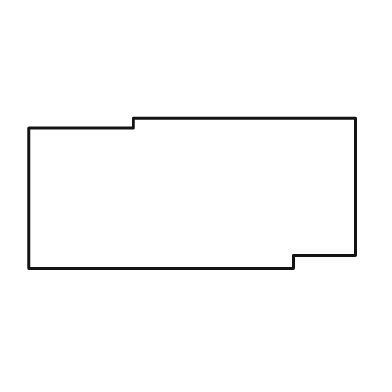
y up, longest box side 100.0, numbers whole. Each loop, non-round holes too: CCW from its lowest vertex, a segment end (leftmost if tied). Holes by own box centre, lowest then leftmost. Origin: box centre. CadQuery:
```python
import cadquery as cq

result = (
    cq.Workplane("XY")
    .moveTo(-50.0, -23.0)
    .lineTo(31.0, -23.0)
    .lineTo(31.0, -19.0)
    .lineTo(50.0, -19.0)
    .lineTo(50.0, 23.0)
    .lineTo(-18.0, 23.0)
    .lineTo(-18.0, 20.0)
    .lineTo(-50.0, 20.0)
    .close()
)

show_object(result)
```